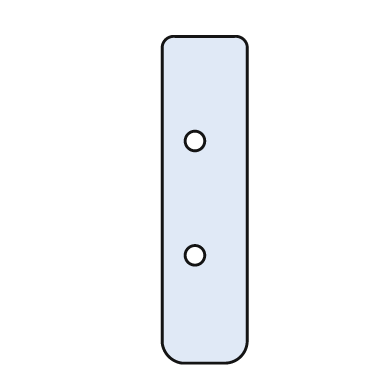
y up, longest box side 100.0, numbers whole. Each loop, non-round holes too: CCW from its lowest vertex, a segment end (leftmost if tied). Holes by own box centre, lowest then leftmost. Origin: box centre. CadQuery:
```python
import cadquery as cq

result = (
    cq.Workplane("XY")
    .moveTo(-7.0, -50.0)
    .lineTo(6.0, -50.0)
    .threePointArc((11.0, -48.0), (13.0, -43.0))
    .lineTo(13.0, 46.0)
    .threePointArc((12.0, 49.0), (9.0, 50.0))
    .lineTo(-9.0, 50.0)
    .threePointArc((-12.0, 49.0), (-13.0, 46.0))
    .lineTo(-13.0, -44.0)
    .threePointArc((-11.0, -48.0), (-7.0, -50.0))
    .close()
    .moveTo(-3.0, -17.0)
    .circle(3.0)
    .moveTo(-3.0, 18.0)
    .circle(3.0)
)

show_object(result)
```